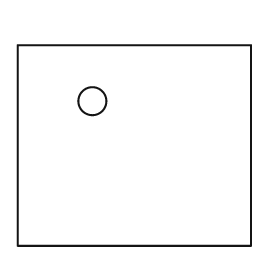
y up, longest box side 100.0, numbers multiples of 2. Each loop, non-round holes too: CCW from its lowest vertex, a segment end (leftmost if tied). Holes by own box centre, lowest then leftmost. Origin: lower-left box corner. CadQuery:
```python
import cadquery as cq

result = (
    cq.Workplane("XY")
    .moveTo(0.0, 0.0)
    .lineTo(100.0, 0.0)
    .lineTo(100.0, 86.0)
    .lineTo(0.0, 86.0)
    .close()
    .moveTo(32.0, 62.0)
    .circle(6.0)
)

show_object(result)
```